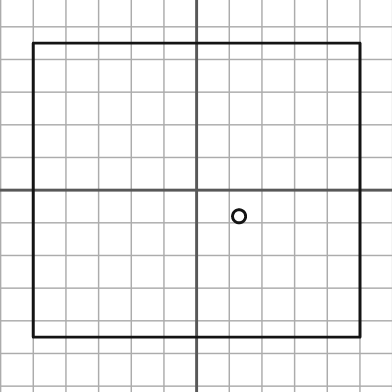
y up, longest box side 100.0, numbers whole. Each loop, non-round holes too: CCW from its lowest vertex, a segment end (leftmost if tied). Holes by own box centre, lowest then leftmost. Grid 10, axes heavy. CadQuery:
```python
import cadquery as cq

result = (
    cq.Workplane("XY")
    .moveTo(-50.0, -45.0)
    .lineTo(50.0, -45.0)
    .lineTo(50.0, 45.0)
    .lineTo(-50.0, 45.0)
    .close()
    .moveTo(13.0, -8.0)
    .circle(2.0)
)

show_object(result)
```